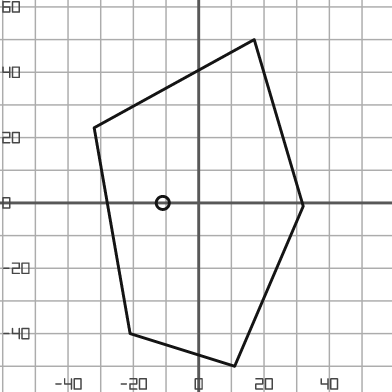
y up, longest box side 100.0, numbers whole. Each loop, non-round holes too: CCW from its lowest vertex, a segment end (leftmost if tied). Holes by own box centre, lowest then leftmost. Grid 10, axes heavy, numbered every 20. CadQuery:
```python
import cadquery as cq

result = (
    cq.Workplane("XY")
    .moveTo(11.0, -50.0)
    .lineTo(32.0, -1.0)
    .lineTo(17.0, 50.0)
    .lineTo(-32.0, 23.0)
    .lineTo(-21.0, -40.0)
    .close()
    .moveTo(-11.0, 0.0)
    .circle(2.0)
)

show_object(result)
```